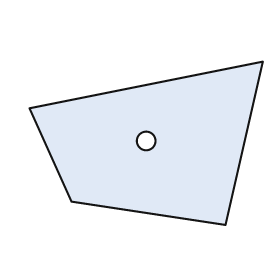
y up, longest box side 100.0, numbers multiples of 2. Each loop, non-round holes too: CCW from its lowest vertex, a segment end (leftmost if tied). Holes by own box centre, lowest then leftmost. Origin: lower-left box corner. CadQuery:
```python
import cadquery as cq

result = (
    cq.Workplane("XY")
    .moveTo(84.0, 0.0)
    .lineTo(100.0, 70.0)
    .lineTo(0.0, 50.0)
    .lineTo(18.0, 10.0)
    .close()
    .moveTo(50.0, 36.0)
    .circle(4.0)
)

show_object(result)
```